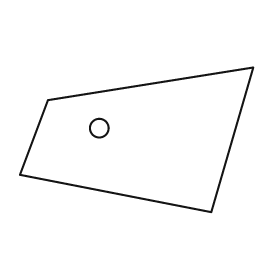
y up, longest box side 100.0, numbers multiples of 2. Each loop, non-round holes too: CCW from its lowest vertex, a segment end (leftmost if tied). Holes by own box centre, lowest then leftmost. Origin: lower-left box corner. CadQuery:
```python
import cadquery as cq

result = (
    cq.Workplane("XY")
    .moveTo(82.0, 0.0)
    .lineTo(100.0, 62.0)
    .lineTo(12.0, 48.0)
    .lineTo(0.0, 16.0)
    .close()
    .moveTo(34.0, 36.0)
    .circle(4.0)
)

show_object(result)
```